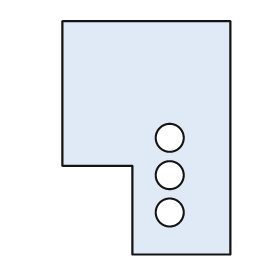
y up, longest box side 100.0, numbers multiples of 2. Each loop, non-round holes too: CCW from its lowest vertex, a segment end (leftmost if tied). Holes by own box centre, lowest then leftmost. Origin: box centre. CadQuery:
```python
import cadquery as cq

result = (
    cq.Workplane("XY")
    .moveTo(-6.0, -50.0)
    .lineTo(36.0, -50.0)
    .lineTo(36.0, 50.0)
    .lineTo(-36.0, 50.0)
    .lineTo(-36.0, -12.0)
    .lineTo(-6.0, -12.0)
    .close()
    .moveTo(10.0, -32.0)
    .circle(6.0)
    .moveTo(10.0, -16.0)
    .circle(6.0)
    .moveTo(10.0, 0.0)
    .circle(6.0)
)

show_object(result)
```